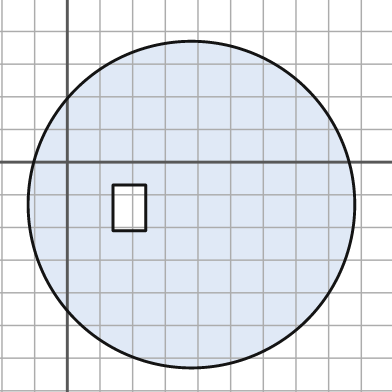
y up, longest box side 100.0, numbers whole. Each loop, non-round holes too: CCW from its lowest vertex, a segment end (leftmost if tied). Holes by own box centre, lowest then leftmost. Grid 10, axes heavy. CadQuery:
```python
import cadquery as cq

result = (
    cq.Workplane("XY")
    .moveTo(38.0, -13.0)
    .circle(50.0)
    .moveTo(14.0, -21.0)
    .lineTo(24.0, -21.0)
    .lineTo(24.0, -7.0)
    .lineTo(14.0, -7.0)
    .close()
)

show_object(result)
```